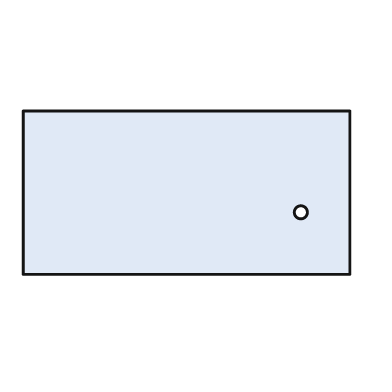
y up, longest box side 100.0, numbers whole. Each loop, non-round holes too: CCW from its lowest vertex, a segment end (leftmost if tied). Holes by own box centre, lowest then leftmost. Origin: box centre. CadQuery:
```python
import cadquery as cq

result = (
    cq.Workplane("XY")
    .moveTo(-50.0, -25.0)
    .lineTo(50.0, -25.0)
    .lineTo(50.0, 25.0)
    .lineTo(-50.0, 25.0)
    .close()
    .moveTo(35.0, -6.0)
    .circle(2.0)
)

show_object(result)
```